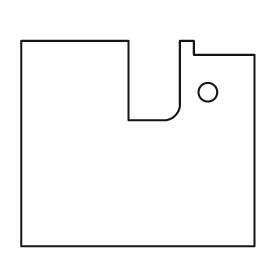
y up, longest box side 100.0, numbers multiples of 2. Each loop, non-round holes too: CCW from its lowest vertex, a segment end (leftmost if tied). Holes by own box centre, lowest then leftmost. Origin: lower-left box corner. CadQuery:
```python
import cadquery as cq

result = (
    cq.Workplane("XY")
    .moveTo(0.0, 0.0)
    .lineTo(100.0, 0.0)
    .lineTo(100.0, 82.0)
    .lineTo(74.0, 82.0)
    .lineTo(74.0, 88.0)
    .lineTo(68.0, 88.0)
    .lineTo(68.0, 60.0)
    .threePointArc((66.0, 56.0), (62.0, 54.0))
    .lineTo(46.0, 54.0)
    .lineTo(46.0, 88.0)
    .lineTo(0.0, 88.0)
    .close()
    .moveTo(80.0, 66.0)
    .circle(4.0)
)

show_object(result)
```